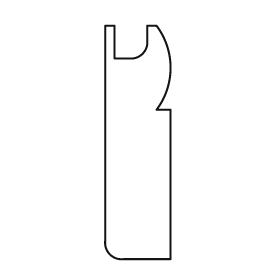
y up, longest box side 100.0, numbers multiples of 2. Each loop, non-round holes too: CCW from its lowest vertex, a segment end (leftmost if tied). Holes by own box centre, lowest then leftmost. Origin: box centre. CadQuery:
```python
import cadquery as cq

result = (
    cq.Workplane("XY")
    .moveTo(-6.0, -50.0)
    .lineTo(14.0, -50.0)
    .lineTo(14.0, 14.0)
    .lineTo(8.0, 14.0)
    .threePointArc((14.0, 32.0), (8.0, 50.0))
    .lineTo(4.0, 50.0)
    .lineTo(4.0, 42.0)
    .threePointArc((2.0, 38.0), (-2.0, 36.0))
    .lineTo(-10.0, 36.0)
    .lineTo(-10.0, 50.0)
    .lineTo(-14.0, 50.0)
    .lineTo(-14.0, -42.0)
    .threePointArc((-12.0, -48.0), (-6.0, -50.0))
    .close()
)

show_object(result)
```